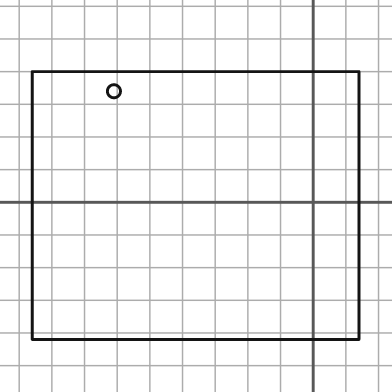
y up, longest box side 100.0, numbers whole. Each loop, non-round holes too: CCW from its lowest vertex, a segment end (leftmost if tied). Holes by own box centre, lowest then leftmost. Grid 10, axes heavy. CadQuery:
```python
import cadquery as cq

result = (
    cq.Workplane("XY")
    .moveTo(-86.0, -42.0)
    .lineTo(14.0, -42.0)
    .lineTo(14.0, 40.0)
    .lineTo(-86.0, 40.0)
    .close()
    .moveTo(-61.0, 34.0)
    .circle(2.0)
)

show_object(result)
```